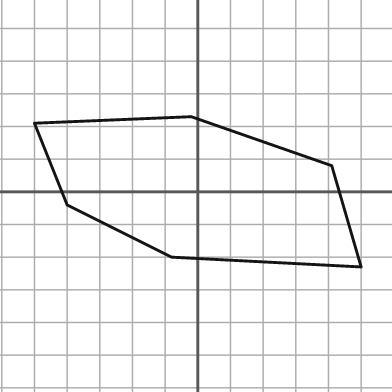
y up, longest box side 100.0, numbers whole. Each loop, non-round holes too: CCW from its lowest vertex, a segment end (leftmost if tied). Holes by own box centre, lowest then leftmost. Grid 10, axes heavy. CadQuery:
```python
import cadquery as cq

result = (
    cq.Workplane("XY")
    .moveTo(50.0, -23.0)
    .lineTo(41.0, 8.0)
    .lineTo(-2.0, 23.0)
    .lineTo(-50.0, 21.0)
    .lineTo(-40.0, -4.0)
    .lineTo(-8.0, -20.0)
    .close()
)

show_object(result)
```